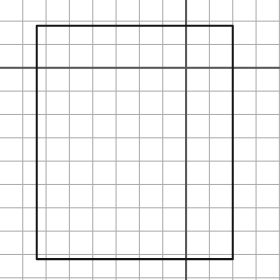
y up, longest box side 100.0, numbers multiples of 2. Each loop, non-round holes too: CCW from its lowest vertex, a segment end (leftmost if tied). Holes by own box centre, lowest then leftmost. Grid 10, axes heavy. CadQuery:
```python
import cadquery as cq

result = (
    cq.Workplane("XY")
    .moveTo(-64.0, -82.0)
    .lineTo(20.0, -82.0)
    .lineTo(20.0, 18.0)
    .lineTo(-64.0, 18.0)
    .close()
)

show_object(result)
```